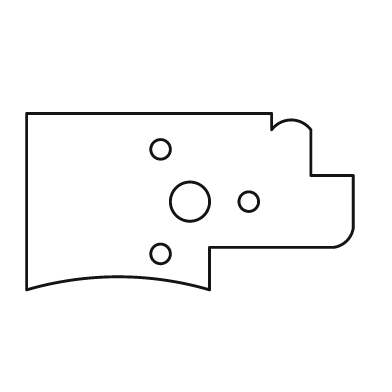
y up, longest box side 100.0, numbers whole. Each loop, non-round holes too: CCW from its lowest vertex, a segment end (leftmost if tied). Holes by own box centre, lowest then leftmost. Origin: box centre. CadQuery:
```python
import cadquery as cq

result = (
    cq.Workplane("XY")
    .moveTo(-50.0, -27.0)
    .threePointArc((-22.0, -23.0), (6.0, -27.0))
    .lineTo(6.0, -14.0)
    .lineTo(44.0, -14.0)
    .threePointArc((48.0, -12.0), (50.0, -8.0))
    .lineTo(50.0, 8.0)
    .lineTo(37.0, 8.0)
    .lineTo(37.0, 22.0)
    .threePointArc((31.0, 25.0), (25.0, 22.0))
    .lineTo(25.0, 27.0)
    .lineTo(-50.0, 27.0)
    .close()
    .moveTo(-9.0, -16.0)
    .circle(3.0)
    .moveTo(0.0, 0.0)
    .circle(6.0)
    .moveTo(18.0, 0.0)
    .circle(3.0)
    .moveTo(-9.0, 16.0)
    .circle(3.0)
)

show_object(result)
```